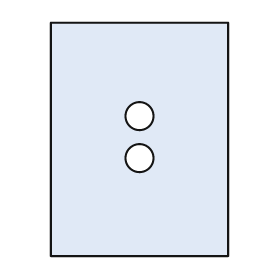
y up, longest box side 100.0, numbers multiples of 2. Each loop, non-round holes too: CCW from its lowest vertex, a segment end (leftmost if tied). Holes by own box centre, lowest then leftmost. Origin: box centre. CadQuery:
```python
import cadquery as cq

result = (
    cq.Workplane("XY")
    .moveTo(-38.0, -50.0)
    .lineTo(38.0, -50.0)
    .lineTo(38.0, 50.0)
    .lineTo(-38.0, 50.0)
    .close()
    .moveTo(0.0, -8.0)
    .circle(6.0)
    .moveTo(0.0, 10.0)
    .circle(6.0)
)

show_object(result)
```